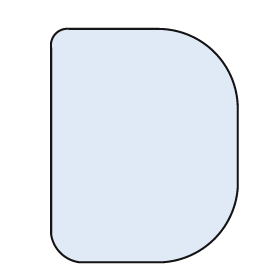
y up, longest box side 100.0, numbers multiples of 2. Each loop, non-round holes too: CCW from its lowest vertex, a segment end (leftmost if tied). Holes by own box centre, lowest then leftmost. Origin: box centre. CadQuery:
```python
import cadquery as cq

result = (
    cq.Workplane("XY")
    .moveTo(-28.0, -50.0)
    .lineTo(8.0, -50.0)
    .threePointArc((30.0, -40.0), (40.0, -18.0))
    .lineTo(40.0, 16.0)
    .threePointArc((30.0, 40.0), (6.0, 50.0))
    .lineTo(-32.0, 50.0)
    .threePointArc((-38.0, 48.0), (-40.0, 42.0))
    .lineTo(-40.0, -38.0)
    .threePointArc((-36.0, -46.0), (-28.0, -50.0))
    .close()
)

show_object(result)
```